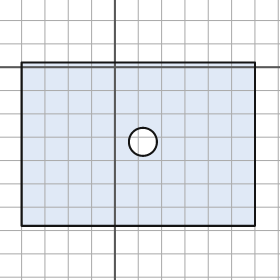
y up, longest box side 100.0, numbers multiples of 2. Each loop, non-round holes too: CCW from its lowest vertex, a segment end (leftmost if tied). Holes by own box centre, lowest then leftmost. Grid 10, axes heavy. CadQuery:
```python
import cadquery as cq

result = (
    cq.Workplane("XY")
    .moveTo(-40.0, -68.0)
    .lineTo(60.0, -68.0)
    .lineTo(60.0, 2.0)
    .lineTo(-40.0, 2.0)
    .close()
    .moveTo(12.0, -32.0)
    .circle(6.0)
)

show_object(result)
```